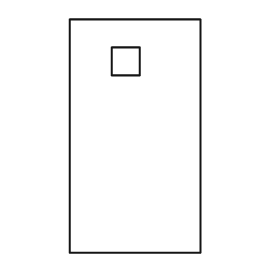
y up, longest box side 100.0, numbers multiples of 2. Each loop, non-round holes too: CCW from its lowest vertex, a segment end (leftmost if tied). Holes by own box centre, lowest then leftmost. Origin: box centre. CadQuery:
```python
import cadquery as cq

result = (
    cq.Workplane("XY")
    .moveTo(-28.0, -50.0)
    .lineTo(28.0, -50.0)
    .lineTo(28.0, 50.0)
    .lineTo(-28.0, 50.0)
    .close()
    .moveTo(-10.0, 26.0)
    .lineTo(2.0, 26.0)
    .lineTo(2.0, 38.0)
    .lineTo(-10.0, 38.0)
    .close()
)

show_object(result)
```